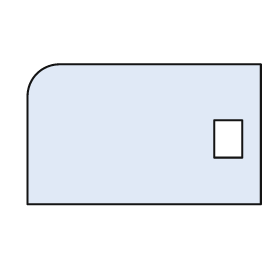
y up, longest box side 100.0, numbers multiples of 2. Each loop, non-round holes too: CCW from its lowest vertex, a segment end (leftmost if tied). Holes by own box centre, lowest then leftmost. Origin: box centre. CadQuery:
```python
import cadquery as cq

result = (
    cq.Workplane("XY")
    .moveTo(-50.0, -30.0)
    .lineTo(50.0, -30.0)
    .lineTo(50.0, 30.0)
    .lineTo(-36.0, 30.0)
    .threePointArc((-46.0, 26.0), (-50.0, 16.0))
    .close()
    .moveTo(30.0, -10.0)
    .lineTo(42.0, -10.0)
    .lineTo(42.0, 6.0)
    .lineTo(30.0, 6.0)
    .close()
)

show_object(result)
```